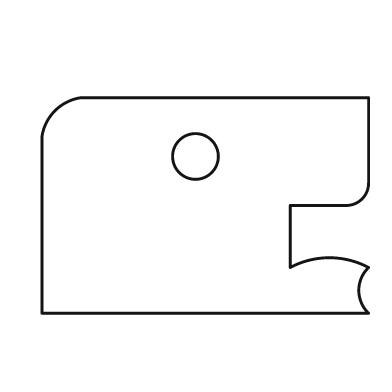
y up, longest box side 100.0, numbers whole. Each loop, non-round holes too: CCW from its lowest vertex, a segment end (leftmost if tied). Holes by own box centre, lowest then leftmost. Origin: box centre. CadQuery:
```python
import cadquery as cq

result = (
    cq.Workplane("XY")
    .moveTo(-50.0, -33.0)
    .lineTo(50.0, -33.0)
    .threePointArc((47.0, -26.0), (50.0, -19.0))
    .threePointArc((38.0, -16.0), (26.0, -19.0))
    .lineTo(26.0, 0.0)
    .lineTo(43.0, 0.0)
    .threePointArc((48.0, 2.0), (50.0, 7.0))
    .lineTo(50.0, 33.0)
    .lineTo(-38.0, 33.0)
    .threePointArc((-46.0, 29.0), (-50.0, 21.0))
    .close()
    .moveTo(-3.0, 15.0)
    .circle(7.0)
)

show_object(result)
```